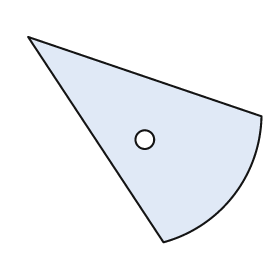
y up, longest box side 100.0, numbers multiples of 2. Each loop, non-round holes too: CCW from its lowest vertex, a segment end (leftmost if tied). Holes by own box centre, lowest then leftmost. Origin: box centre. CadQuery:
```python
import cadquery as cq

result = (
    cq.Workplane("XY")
    .moveTo(8.0, -44.0)
    .threePointArc((38.0, -24.0), (50.0, 10.0))
    .lineTo(-50.0, 44.0)
    .close()
    .moveTo(0.0, 0.0)
    .circle(4.0)
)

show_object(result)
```